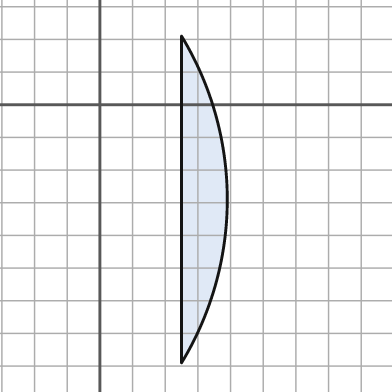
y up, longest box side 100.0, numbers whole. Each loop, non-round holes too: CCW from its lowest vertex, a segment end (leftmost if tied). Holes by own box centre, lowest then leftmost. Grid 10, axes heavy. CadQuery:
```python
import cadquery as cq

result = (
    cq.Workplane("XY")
    .moveTo(25.0, -79.0)
    .threePointArc((39.0, -29.0), (25.0, 21.0))
    .close()
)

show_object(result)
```